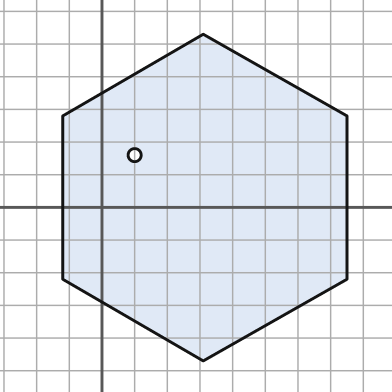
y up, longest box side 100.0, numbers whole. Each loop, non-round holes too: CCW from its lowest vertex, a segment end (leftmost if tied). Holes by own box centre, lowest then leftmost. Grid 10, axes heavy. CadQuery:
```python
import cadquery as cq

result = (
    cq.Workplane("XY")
    .moveTo(31.0, -47.0)
    .lineTo(75.0, -22.0)
    .lineTo(75.0, 28.0)
    .lineTo(31.0, 53.0)
    .lineTo(-12.0, 28.0)
    .lineTo(-12.0, -22.0)
    .close()
    .moveTo(10.0, 16.0)
    .circle(2.0)
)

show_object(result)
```